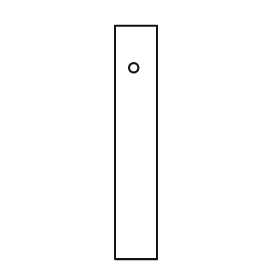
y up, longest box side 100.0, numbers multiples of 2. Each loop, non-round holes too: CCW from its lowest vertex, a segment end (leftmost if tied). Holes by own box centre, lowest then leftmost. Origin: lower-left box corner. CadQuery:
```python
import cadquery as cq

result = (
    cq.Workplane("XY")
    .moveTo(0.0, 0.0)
    .lineTo(18.0, 0.0)
    .lineTo(18.0, 100.0)
    .lineTo(0.0, 100.0)
    .close()
    .moveTo(8.0, 82.0)
    .circle(2.0)
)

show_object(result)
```